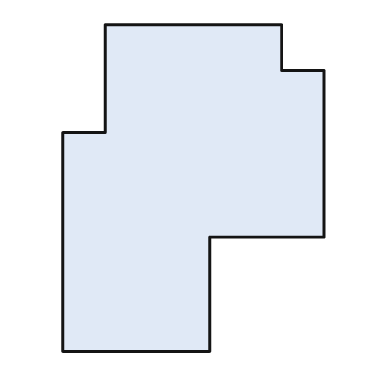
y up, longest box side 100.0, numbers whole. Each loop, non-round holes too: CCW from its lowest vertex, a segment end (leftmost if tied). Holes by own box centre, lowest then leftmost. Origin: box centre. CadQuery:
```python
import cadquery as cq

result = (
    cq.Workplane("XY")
    .moveTo(-40.0, -50.0)
    .lineTo(5.0, -50.0)
    .lineTo(5.0, -15.0)
    .lineTo(40.0, -15.0)
    .lineTo(40.0, 36.0)
    .lineTo(27.0, 36.0)
    .lineTo(27.0, 50.0)
    .lineTo(-27.0, 50.0)
    .lineTo(-27.0, 17.0)
    .lineTo(-40.0, 17.0)
    .close()
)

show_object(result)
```